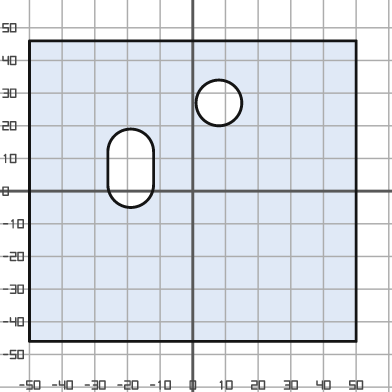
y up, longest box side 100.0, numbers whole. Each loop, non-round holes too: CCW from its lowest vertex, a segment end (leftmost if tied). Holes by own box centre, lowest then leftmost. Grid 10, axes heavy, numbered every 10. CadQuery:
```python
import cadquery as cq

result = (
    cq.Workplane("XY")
    .moveTo(-50.0, -46.0)
    .lineTo(50.0, -46.0)
    .lineTo(50.0, 46.0)
    .lineTo(-50.0, 46.0)
    .close()
    .moveTo(-26.0, 2.0)
    .threePointArc((-19.0, -5.0), (-12.0, 2.0))
    .lineTo(-12.0, 12.0)
    .threePointArc((-19.0, 19.0), (-26.0, 12.0))
    .close()
    .moveTo(8.0, 27.0)
    .circle(7.0)
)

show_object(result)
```